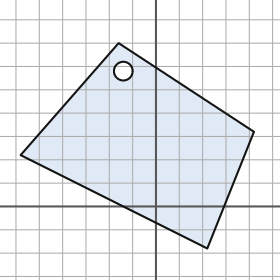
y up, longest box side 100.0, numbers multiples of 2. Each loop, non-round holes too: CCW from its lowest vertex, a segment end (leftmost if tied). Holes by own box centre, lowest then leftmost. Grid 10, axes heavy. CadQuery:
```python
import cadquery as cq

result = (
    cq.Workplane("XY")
    .moveTo(22.0, -18.0)
    .lineTo(42.0, 32.0)
    .lineTo(-16.0, 70.0)
    .lineTo(-58.0, 22.0)
    .close()
    .moveTo(-14.0, 58.0)
    .circle(4.0)
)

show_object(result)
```